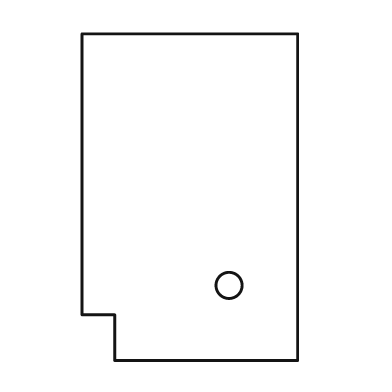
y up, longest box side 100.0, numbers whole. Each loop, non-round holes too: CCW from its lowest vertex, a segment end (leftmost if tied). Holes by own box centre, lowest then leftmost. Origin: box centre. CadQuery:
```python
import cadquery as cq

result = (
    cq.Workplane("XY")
    .moveTo(-23.0, -50.0)
    .lineTo(33.0, -50.0)
    .lineTo(33.0, 50.0)
    .lineTo(-33.0, 50.0)
    .lineTo(-33.0, -36.0)
    .lineTo(-23.0, -36.0)
    .close()
    .moveTo(12.0, -27.0)
    .circle(4.0)
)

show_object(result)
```